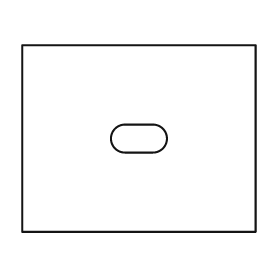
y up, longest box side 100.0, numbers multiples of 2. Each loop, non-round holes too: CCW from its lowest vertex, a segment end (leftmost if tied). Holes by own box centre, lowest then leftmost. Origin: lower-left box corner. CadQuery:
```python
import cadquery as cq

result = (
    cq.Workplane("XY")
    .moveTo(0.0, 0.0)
    .lineTo(100.0, 0.0)
    .lineTo(100.0, 80.0)
    .lineTo(0.0, 80.0)
    .close()
    .moveTo(44.0, 34.0)
    .lineTo(56.0, 34.0)
    .threePointArc((62.0, 40.0), (56.0, 46.0))
    .lineTo(44.0, 46.0)
    .threePointArc((38.0, 40.0), (44.0, 34.0))
    .close()
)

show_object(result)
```